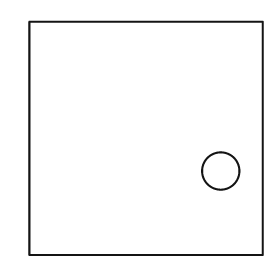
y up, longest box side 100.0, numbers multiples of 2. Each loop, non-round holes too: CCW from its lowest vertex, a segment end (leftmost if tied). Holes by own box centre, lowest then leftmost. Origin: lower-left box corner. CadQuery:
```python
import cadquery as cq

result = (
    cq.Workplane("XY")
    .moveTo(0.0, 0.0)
    .lineTo(100.0, 0.0)
    .lineTo(100.0, 100.0)
    .lineTo(0.0, 100.0)
    .close()
    .moveTo(82.0, 36.0)
    .circle(8.0)
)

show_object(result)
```